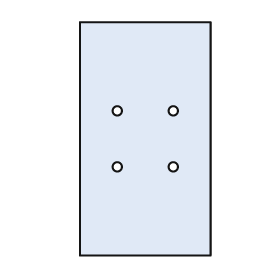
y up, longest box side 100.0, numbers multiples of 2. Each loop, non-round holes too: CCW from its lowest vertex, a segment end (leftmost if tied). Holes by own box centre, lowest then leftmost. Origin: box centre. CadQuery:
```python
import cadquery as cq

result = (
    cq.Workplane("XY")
    .moveTo(-28.0, -50.0)
    .lineTo(28.0, -50.0)
    .lineTo(28.0, 50.0)
    .lineTo(-28.0, 50.0)
    .close()
    .moveTo(-12.0, -12.0)
    .circle(2.0)
    .moveTo(12.0, -12.0)
    .circle(2.0)
    .moveTo(-12.0, 12.0)
    .circle(2.0)
    .moveTo(12.0, 12.0)
    .circle(2.0)
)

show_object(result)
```